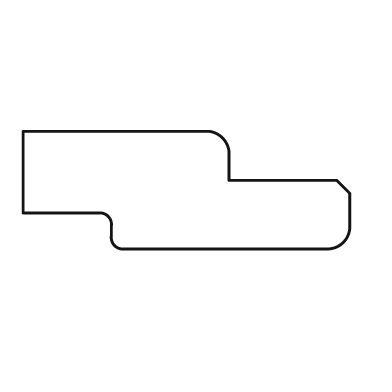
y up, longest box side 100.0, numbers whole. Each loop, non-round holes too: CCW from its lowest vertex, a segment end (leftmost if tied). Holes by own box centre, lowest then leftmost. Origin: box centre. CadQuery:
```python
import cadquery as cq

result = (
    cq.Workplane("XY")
    .moveTo(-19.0, -18.0)
    .lineTo(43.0, -18.0)
    .threePointArc((48.0, -16.0), (50.0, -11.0))
    .lineTo(50.0, -1.0)
    .lineTo(46.0, 3.0)
    .lineTo(13.0, 3.0)
    .lineTo(13.0, 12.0)
    .threePointArc((11.0, 16.0), (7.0, 18.0))
    .lineTo(-50.0, 18.0)
    .lineTo(-50.0, -7.0)
    .lineTo(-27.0, -7.0)
    .threePointArc((-24.0, -8.0), (-23.0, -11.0))
    .lineTo(-23.0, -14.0)
    .threePointArc((-22.0, -17.0), (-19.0, -18.0))
    .close()
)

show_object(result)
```